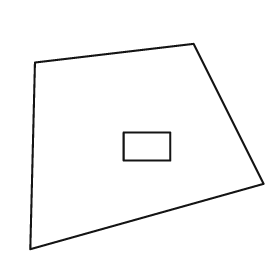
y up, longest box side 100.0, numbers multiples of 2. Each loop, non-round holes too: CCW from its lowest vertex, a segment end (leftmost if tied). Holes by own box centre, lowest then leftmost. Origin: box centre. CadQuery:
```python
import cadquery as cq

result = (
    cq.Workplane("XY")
    .moveTo(-50.0, -44.0)
    .lineTo(50.0, -16.0)
    .lineTo(20.0, 44.0)
    .lineTo(-48.0, 36.0)
    .close()
    .moveTo(-10.0, -6.0)
    .lineTo(10.0, -6.0)
    .lineTo(10.0, 6.0)
    .lineTo(-10.0, 6.0)
    .close()
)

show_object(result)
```